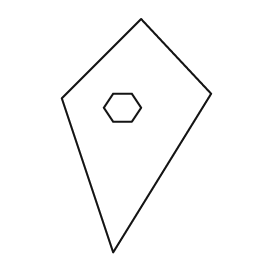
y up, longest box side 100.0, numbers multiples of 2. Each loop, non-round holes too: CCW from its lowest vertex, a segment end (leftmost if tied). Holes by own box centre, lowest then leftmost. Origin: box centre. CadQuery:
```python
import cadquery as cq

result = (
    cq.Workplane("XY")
    .moveTo(-10.0, -50.0)
    .lineTo(32.0, 18.0)
    .lineTo(2.0, 50.0)
    .lineTo(-32.0, 16.0)
    .close()
    .moveTo(-10.0, 6.0)
    .lineTo(-2.0, 6.0)
    .lineTo(2.0, 12.0)
    .lineTo(-2.0, 18.0)
    .lineTo(-10.0, 18.0)
    .lineTo(-14.0, 12.0)
    .close()
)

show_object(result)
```